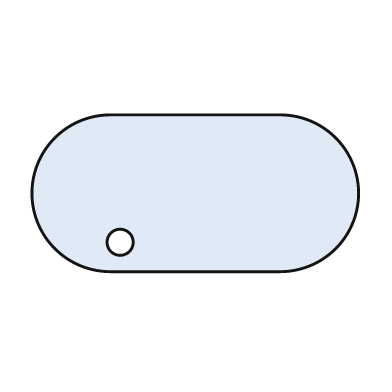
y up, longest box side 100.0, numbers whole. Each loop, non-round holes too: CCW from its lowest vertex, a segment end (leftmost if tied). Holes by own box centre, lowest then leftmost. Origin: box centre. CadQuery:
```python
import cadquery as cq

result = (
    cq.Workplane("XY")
    .moveTo(-26.0, -24.0)
    .lineTo(26.0, -24.0)
    .threePointArc((50.0, 0.0), (26.0, 24.0))
    .lineTo(-26.0, 24.0)
    .threePointArc((-50.0, 0.0), (-26.0, -24.0))
    .close()
    .moveTo(-23.0, -15.0)
    .circle(4.0)
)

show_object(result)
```